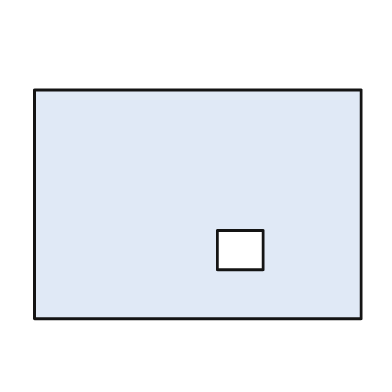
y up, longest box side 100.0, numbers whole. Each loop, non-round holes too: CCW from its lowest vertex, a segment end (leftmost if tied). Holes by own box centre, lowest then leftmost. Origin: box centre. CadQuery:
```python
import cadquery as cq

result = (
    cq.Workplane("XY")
    .moveTo(-50.0, -35.0)
    .lineTo(50.0, -35.0)
    .lineTo(50.0, 35.0)
    .lineTo(-50.0, 35.0)
    .close()
    .moveTo(6.0, -20.0)
    .lineTo(20.0, -20.0)
    .lineTo(20.0, -8.0)
    .lineTo(6.0, -8.0)
    .close()
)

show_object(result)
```